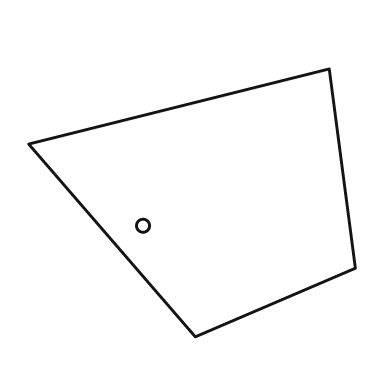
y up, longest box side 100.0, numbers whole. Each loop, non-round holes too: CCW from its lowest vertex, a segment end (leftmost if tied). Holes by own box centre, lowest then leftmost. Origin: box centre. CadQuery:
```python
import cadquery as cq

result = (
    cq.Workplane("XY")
    .moveTo(1.0, -41.0)
    .lineTo(50.0, -20.0)
    .lineTo(42.0, 41.0)
    .lineTo(-50.0, 18.0)
    .close()
    .moveTo(-15.0, -7.0)
    .circle(2.0)
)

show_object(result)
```